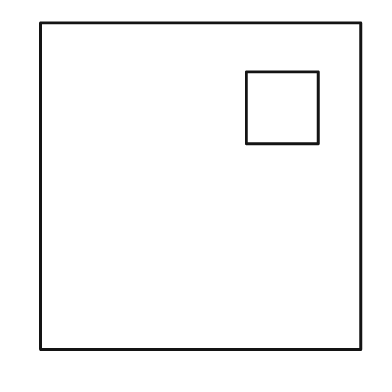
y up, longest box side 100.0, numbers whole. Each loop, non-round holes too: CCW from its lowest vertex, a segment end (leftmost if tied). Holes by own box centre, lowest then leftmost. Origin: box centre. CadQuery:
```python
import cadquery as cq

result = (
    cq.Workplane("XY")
    .moveTo(-49.0, -50.0)
    .lineTo(49.0, -50.0)
    .lineTo(49.0, 50.0)
    .lineTo(-49.0, 50.0)
    .close()
    .moveTo(14.0, 13.0)
    .lineTo(36.0, 13.0)
    .lineTo(36.0, 35.0)
    .lineTo(14.0, 35.0)
    .close()
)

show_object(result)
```